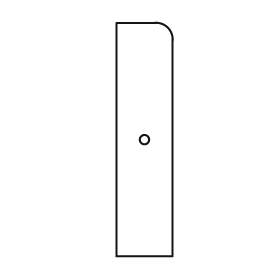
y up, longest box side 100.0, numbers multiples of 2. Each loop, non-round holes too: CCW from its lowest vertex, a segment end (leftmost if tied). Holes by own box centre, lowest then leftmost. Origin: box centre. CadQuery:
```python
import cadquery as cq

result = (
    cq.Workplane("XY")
    .moveTo(-12.0, -50.0)
    .lineTo(12.0, -50.0)
    .lineTo(12.0, 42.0)
    .threePointArc((10.0, 48.0), (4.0, 50.0))
    .lineTo(-12.0, 50.0)
    .close()
    .moveTo(0.0, 0.0)
    .circle(2.0)
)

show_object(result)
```